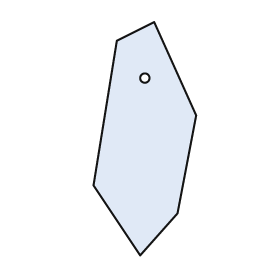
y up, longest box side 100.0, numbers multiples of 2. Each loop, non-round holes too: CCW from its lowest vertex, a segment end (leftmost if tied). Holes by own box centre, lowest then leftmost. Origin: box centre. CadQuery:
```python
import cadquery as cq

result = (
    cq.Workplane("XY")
    .moveTo(-2.0, -50.0)
    .lineTo(14.0, -32.0)
    .lineTo(22.0, 10.0)
    .lineTo(4.0, 50.0)
    .lineTo(-12.0, 42.0)
    .lineTo(-22.0, -20.0)
    .close()
    .moveTo(0.0, 26.0)
    .circle(2.0)
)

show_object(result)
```